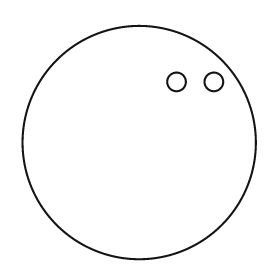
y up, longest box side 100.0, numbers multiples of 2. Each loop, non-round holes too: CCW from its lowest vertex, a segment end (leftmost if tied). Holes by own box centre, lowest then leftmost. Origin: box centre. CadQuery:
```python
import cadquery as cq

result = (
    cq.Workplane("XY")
    .moveTo(0.0, 0.0)
    .circle(50.0)
    .moveTo(16.0, 26.0)
    .circle(4.0)
    .moveTo(32.0, 26.0)
    .circle(4.0)
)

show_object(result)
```